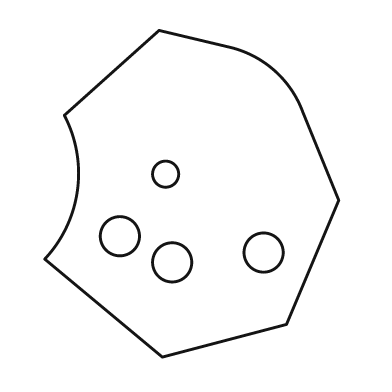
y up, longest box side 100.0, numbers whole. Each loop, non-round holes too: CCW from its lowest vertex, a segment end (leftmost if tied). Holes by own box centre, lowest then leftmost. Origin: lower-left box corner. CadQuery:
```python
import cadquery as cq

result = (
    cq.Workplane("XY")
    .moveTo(36.0, 0.0)
    .lineTo(74.0, 10.0)
    .lineTo(90.0, 48.0)
    .lineTo(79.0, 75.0)
    .threePointArc((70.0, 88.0), (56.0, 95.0))
    .lineTo(35.0, 100.0)
    .lineTo(6.0, 74.0)
    .threePointArc((10.0, 51.0), (0.0, 30.0))
    .close()
    .moveTo(39.0, 29.0)
    .circle(6.0)
    .moveTo(67.0, 32.0)
    .circle(6.0)
    .moveTo(23.0, 37.0)
    .circle(6.0)
    .moveTo(37.0, 56.0)
    .circle(4.0)
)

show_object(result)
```